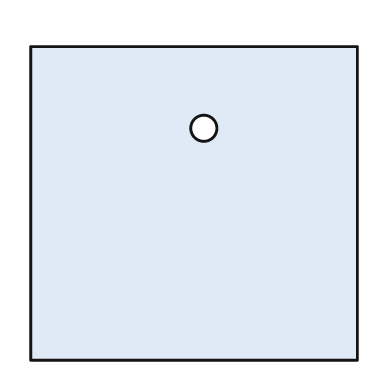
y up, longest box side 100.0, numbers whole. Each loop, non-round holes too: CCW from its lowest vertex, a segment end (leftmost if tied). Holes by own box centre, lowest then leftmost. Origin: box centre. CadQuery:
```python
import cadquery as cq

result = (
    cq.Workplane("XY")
    .moveTo(-50.0, -48.0)
    .lineTo(50.0, -48.0)
    .lineTo(50.0, 48.0)
    .lineTo(-50.0, 48.0)
    .close()
    .moveTo(3.0, 23.0)
    .circle(4.0)
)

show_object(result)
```